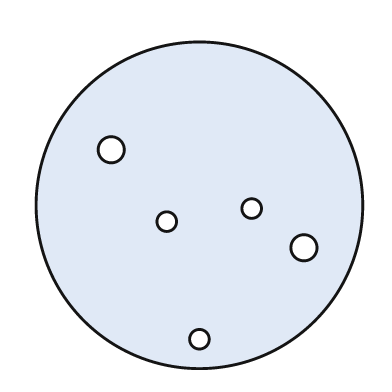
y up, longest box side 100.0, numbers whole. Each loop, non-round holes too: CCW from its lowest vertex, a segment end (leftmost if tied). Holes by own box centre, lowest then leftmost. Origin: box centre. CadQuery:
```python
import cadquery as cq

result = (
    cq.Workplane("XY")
    .moveTo(0.0, 0.0)
    .circle(50.0)
    .moveTo(0.0, -41.0)
    .circle(3.0)
    .moveTo(32.0, -13.0)
    .circle(4.0)
    .moveTo(-10.0, -5.0)
    .circle(3.0)
    .moveTo(16.0, -1.0)
    .circle(3.0)
    .moveTo(-27.0, 17.0)
    .circle(4.0)
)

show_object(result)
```